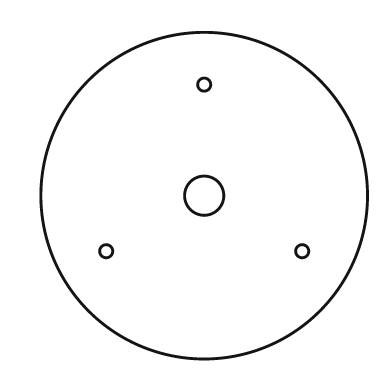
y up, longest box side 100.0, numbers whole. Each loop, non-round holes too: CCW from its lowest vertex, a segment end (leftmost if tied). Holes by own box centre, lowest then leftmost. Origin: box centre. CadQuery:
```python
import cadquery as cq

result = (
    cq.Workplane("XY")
    .moveTo(0.0, 0.0)
    .circle(50.0)
    .moveTo(-30.0, -17.0)
    .circle(2.0)
    .moveTo(30.0, -17.0)
    .circle(2.0)
    .moveTo(0.0, 0.0)
    .circle(6.0)
    .moveTo(0.0, 34.0)
    .circle(2.0)
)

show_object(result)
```